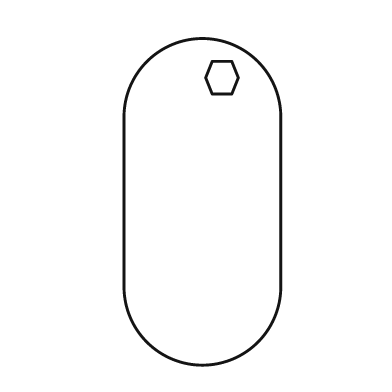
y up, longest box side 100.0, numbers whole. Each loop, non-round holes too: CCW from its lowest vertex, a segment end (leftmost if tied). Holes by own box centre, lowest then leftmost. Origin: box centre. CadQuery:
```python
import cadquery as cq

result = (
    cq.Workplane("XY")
    .moveTo(-24.0, -26.0)
    .threePointArc((0.0, -50.0), (24.0, -26.0))
    .lineTo(24.0, 26.0)
    .threePointArc((0.0, 50.0), (-24.0, 26.0))
    .close()
    .moveTo(3.0, 33.0)
    .lineTo(9.0, 33.0)
    .lineTo(11.0, 38.0)
    .lineTo(9.0, 43.0)
    .lineTo(3.0, 43.0)
    .lineTo(1.0, 38.0)
    .close()
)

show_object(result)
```